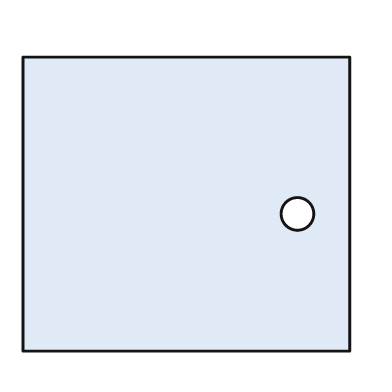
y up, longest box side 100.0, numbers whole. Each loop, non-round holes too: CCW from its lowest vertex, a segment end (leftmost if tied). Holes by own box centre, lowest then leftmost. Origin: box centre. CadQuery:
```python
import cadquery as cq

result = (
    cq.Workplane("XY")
    .moveTo(-50.0, -45.0)
    .lineTo(50.0, -45.0)
    .lineTo(50.0, 45.0)
    .lineTo(-50.0, 45.0)
    .close()
    .moveTo(34.0, -3.0)
    .circle(5.0)
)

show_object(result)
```